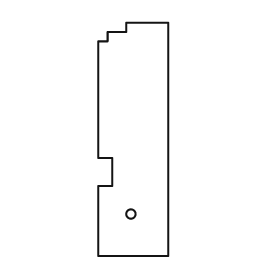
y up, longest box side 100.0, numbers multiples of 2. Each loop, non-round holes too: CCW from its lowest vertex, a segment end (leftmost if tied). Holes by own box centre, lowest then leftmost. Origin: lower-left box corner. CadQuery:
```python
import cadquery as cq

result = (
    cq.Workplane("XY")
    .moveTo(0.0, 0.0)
    .lineTo(30.0, 0.0)
    .lineTo(30.0, 100.0)
    .lineTo(12.0, 100.0)
    .lineTo(12.0, 96.0)
    .lineTo(4.0, 96.0)
    .lineTo(4.0, 92.0)
    .lineTo(0.0, 92.0)
    .lineTo(0.0, 42.0)
    .lineTo(6.0, 42.0)
    .lineTo(6.0, 30.0)
    .lineTo(0.0, 30.0)
    .close()
    .moveTo(14.0, 18.0)
    .circle(2.0)
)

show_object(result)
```